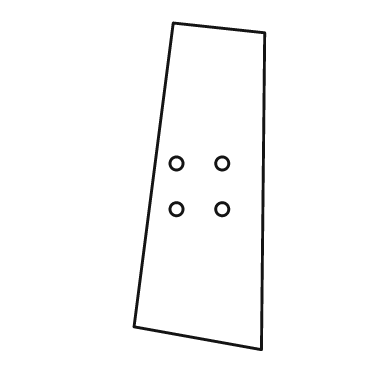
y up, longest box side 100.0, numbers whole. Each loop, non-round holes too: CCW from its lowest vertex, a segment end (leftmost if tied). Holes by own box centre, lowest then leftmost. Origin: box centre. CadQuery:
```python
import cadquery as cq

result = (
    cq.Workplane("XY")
    .moveTo(19.0, -50.0)
    .lineTo(20.0, 47.0)
    .lineTo(-8.0, 50.0)
    .lineTo(-20.0, -43.0)
    .close()
    .moveTo(-7.0, -7.0)
    .circle(2.0)
    .moveTo(7.0, -7.0)
    .circle(2.0)
    .moveTo(-7.0, 7.0)
    .circle(2.0)
    .moveTo(7.0, 7.0)
    .circle(2.0)
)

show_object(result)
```